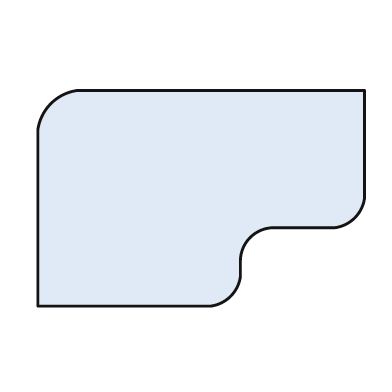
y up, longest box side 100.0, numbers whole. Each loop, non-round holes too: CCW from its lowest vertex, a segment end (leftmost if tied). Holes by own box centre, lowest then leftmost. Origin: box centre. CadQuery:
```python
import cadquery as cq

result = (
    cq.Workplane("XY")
    .moveTo(-50.0, -33.0)
    .lineTo(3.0, -33.0)
    .threePointArc((9.0, -30.0), (12.0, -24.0))
    .lineTo(12.0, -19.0)
    .threePointArc((15.0, -12.0), (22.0, -9.0))
    .lineTo(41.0, -9.0)
    .threePointArc((47.0, -6.0), (50.0, 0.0))
    .lineTo(50.0, 33.0)
    .lineTo(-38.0, 33.0)
    .threePointArc((-46.0, 29.0), (-50.0, 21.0))
    .close()
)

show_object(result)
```